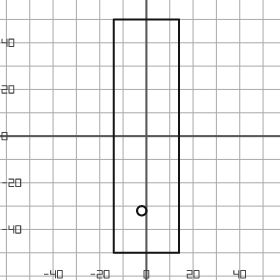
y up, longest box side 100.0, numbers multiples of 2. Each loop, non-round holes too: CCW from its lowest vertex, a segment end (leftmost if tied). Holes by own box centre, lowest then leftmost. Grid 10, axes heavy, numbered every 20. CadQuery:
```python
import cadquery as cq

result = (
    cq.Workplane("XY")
    .moveTo(-14.0, -50.0)
    .lineTo(14.0, -50.0)
    .lineTo(14.0, 50.0)
    .lineTo(-14.0, 50.0)
    .close()
    .moveTo(-2.0, -32.0)
    .circle(2.0)
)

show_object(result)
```